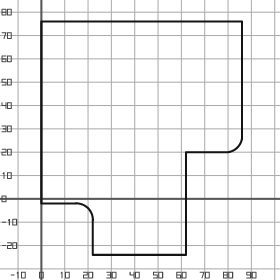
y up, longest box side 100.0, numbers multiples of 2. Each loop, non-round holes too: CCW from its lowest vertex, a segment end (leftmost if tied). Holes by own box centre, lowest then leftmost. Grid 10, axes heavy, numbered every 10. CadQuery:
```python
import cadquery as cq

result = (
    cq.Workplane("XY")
    .moveTo(22.0, -24.0)
    .lineTo(62.0, -24.0)
    .lineTo(62.0, 20.0)
    .lineTo(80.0, 20.0)
    .threePointArc((84.0, 22.0), (86.0, 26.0))
    .lineTo(86.0, 76.0)
    .lineTo(0.0, 76.0)
    .lineTo(0.0, -2.0)
    .lineTo(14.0, -2.0)
    .threePointArc((20.0, -4.0), (22.0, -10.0))
    .close()
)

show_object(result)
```